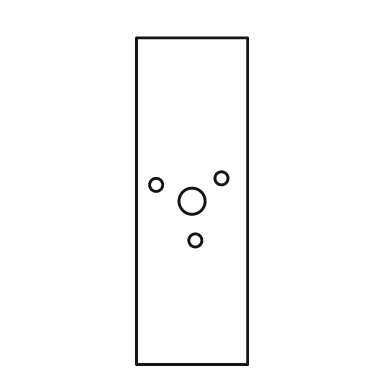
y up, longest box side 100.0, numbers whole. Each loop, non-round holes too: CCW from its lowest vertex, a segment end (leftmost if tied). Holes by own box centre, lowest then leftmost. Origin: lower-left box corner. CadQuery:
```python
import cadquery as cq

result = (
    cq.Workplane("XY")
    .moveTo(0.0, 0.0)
    .lineTo(34.0, 0.0)
    .lineTo(34.0, 100.0)
    .lineTo(0.0, 100.0)
    .close()
    .moveTo(18.0, 38.0)
    .circle(2.0)
    .moveTo(17.0, 50.0)
    .circle(4.0)
    .moveTo(6.0, 55.0)
    .circle(2.0)
    .moveTo(26.0, 57.0)
    .circle(2.0)
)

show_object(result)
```